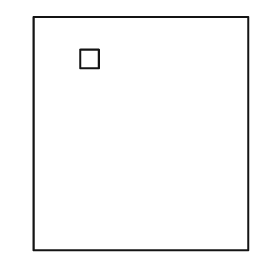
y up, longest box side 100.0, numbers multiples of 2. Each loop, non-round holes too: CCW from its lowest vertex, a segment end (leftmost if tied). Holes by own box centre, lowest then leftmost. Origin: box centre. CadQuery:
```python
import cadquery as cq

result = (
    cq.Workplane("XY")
    .moveTo(-46.0, -50.0)
    .lineTo(46.0, -50.0)
    .lineTo(46.0, 50.0)
    .lineTo(-46.0, 50.0)
    .close()
    .moveTo(-26.0, 28.0)
    .lineTo(-18.0, 28.0)
    .lineTo(-18.0, 36.0)
    .lineTo(-26.0, 36.0)
    .close()
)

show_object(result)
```